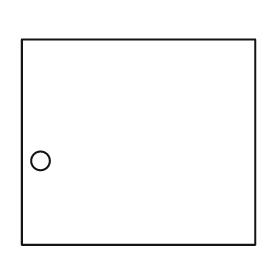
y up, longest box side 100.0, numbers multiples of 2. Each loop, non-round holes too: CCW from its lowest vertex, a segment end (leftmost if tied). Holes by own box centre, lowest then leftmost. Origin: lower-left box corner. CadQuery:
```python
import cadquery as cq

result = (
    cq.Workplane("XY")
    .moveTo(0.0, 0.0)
    .lineTo(100.0, 0.0)
    .lineTo(100.0, 88.0)
    .lineTo(0.0, 88.0)
    .close()
    .moveTo(8.0, 36.0)
    .circle(4.0)
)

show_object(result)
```